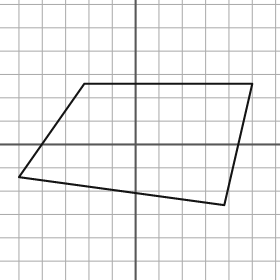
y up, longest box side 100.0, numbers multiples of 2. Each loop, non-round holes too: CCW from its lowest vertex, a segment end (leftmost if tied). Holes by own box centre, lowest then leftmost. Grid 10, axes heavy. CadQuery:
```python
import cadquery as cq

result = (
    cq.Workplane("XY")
    .moveTo(38.0, -26.0)
    .lineTo(50.0, 26.0)
    .lineTo(-22.0, 26.0)
    .lineTo(-50.0, -14.0)
    .close()
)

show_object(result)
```